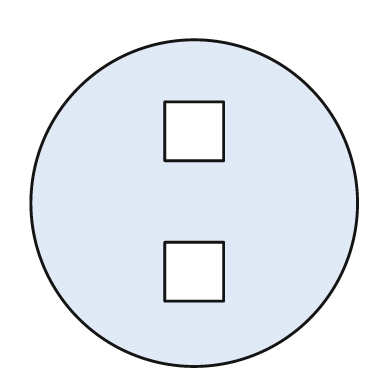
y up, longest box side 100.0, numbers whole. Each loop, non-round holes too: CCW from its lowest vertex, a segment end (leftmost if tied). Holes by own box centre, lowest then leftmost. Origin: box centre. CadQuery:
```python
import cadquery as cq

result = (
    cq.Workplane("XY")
    .moveTo(0.0, 0.0)
    .circle(50.0)
    .moveTo(-9.0, -30.0)
    .lineTo(9.0, -30.0)
    .lineTo(9.0, -12.0)
    .lineTo(-9.0, -12.0)
    .close()
    .moveTo(-9.0, 13.0)
    .lineTo(9.0, 13.0)
    .lineTo(9.0, 31.0)
    .lineTo(-9.0, 31.0)
    .close()
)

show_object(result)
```